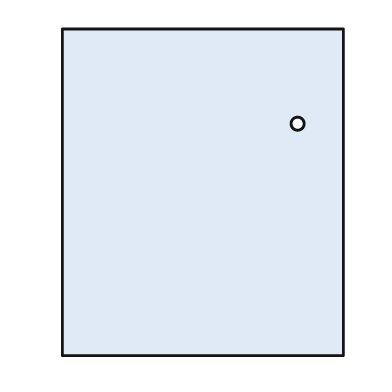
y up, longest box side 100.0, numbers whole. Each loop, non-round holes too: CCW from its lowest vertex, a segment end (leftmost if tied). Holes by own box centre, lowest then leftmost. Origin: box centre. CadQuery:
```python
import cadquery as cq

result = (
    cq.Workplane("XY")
    .moveTo(-43.0, -50.0)
    .lineTo(43.0, -50.0)
    .lineTo(43.0, 50.0)
    .lineTo(-43.0, 50.0)
    .close()
    .moveTo(29.0, 21.0)
    .circle(2.0)
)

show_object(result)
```